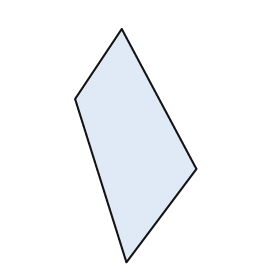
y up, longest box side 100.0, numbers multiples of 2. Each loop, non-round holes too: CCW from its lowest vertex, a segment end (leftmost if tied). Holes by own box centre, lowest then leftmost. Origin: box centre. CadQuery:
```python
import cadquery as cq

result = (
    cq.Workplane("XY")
    .moveTo(-4.0, -50.0)
    .lineTo(26.0, -10.0)
    .lineTo(-6.0, 50.0)
    .lineTo(-26.0, 20.0)
    .close()
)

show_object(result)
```